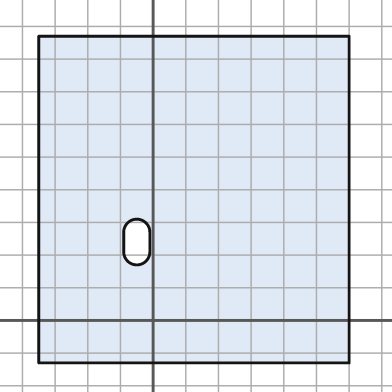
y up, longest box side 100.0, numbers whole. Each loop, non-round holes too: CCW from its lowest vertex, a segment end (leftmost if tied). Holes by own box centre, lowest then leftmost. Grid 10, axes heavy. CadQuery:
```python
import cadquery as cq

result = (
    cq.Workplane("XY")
    .moveTo(-35.0, -13.0)
    .lineTo(60.0, -13.0)
    .lineTo(60.0, 87.0)
    .lineTo(-35.0, 87.0)
    .close()
    .moveTo(-9.0, 21.0)
    .threePointArc((-5.0, 17.0), (-1.0, 21.0))
    .lineTo(-1.0, 27.0)
    .threePointArc((-5.0, 31.0), (-9.0, 27.0))
    .close()
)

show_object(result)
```